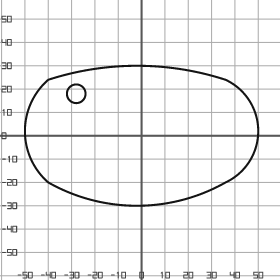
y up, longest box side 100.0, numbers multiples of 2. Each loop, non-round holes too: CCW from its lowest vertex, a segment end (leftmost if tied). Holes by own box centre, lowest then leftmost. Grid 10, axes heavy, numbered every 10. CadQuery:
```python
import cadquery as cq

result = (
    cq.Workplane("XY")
    .moveTo(-40.0, -20.0)
    .threePointArc((-2.0, -30.0), (36.0, -20.0))
    .threePointArc((50.0, 2.0), (36.0, 24.0))
    .threePointArc((-2.0, 30.0), (-40.0, 24.0))
    .threePointArc((-50.0, 2.0), (-40.0, -20.0))
    .close()
    .moveTo(-28.0, 18.0)
    .circle(4.0)
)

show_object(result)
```